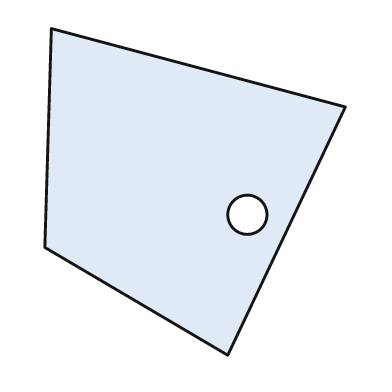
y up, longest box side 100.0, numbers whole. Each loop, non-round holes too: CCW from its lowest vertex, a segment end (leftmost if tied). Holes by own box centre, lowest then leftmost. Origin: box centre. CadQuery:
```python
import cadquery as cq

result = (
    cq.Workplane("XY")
    .moveTo(10.0, -50.0)
    .lineTo(46.0, 26.0)
    .lineTo(-44.0, 50.0)
    .lineTo(-46.0, -17.0)
    .close()
    .moveTo(16.0, -7.0)
    .circle(6.0)
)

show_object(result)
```